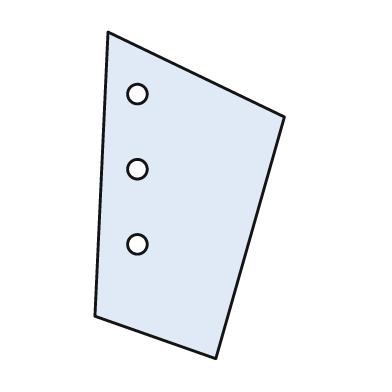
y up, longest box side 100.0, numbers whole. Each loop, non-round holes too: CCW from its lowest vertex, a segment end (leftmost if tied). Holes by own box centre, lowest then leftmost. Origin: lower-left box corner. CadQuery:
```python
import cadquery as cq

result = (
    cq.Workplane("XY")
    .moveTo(37.0, 0.0)
    .lineTo(58.0, 74.0)
    .lineTo(4.0, 100.0)
    .lineTo(0.0, 13.0)
    .close()
    .moveTo(13.0, 35.0)
    .circle(3.0)
    .moveTo(13.0, 58.0)
    .circle(3.0)
    .moveTo(13.0, 81.0)
    .circle(3.0)
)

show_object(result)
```